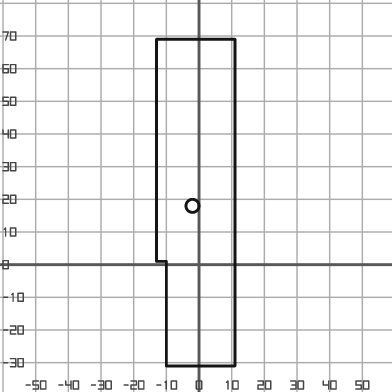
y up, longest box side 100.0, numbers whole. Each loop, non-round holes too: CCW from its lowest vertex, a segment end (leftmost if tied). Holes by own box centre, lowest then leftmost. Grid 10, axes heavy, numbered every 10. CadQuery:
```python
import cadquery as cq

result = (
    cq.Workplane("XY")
    .moveTo(-10.0, -31.0)
    .lineTo(11.0, -31.0)
    .lineTo(11.0, 69.0)
    .lineTo(-13.0, 69.0)
    .lineTo(-13.0, 1.0)
    .lineTo(-10.0, 1.0)
    .close()
    .moveTo(-2.0, 18.0)
    .circle(2.0)
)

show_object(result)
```